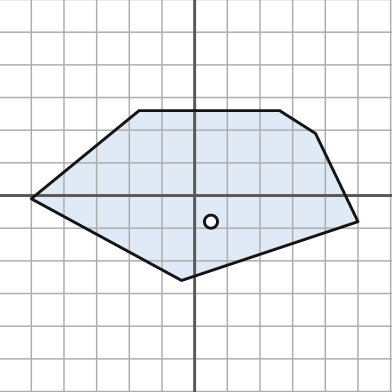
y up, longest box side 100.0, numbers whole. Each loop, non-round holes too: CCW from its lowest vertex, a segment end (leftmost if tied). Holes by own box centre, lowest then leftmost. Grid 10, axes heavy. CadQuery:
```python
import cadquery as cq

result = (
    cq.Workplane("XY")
    .moveTo(-4.0, -26.0)
    .lineTo(50.0, -8.0)
    .lineTo(37.0, 19.0)
    .lineTo(26.0, 26.0)
    .lineTo(-17.0, 26.0)
    .lineTo(-50.0, -1.0)
    .close()
    .moveTo(5.0, -8.0)
    .circle(2.0)
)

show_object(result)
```